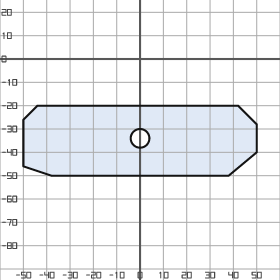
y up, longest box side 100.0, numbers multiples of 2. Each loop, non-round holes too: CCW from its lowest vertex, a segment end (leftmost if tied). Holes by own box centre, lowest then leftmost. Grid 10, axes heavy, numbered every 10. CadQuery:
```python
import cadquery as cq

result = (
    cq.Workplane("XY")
    .moveTo(-38.0, -50.0)
    .lineTo(38.0, -50.0)
    .lineTo(50.0, -40.0)
    .lineTo(50.0, -28.0)
    .lineTo(42.0, -20.0)
    .lineTo(-44.0, -20.0)
    .lineTo(-50.0, -26.0)
    .lineTo(-50.0, -46.0)
    .close()
    .moveTo(0.0, -34.0)
    .circle(4.0)
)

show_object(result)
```